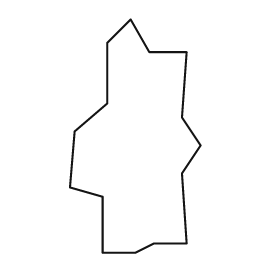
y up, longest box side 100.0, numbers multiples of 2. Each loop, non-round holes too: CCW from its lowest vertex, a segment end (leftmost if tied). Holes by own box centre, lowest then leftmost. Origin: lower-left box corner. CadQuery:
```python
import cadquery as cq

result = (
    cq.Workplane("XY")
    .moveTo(14.0, 0.0)
    .lineTo(28.0, 0.0)
    .lineTo(36.0, 4.0)
    .lineTo(50.0, 4.0)
    .lineTo(48.0, 34.0)
    .lineTo(56.0, 46.0)
    .lineTo(48.0, 58.0)
    .lineTo(50.0, 86.0)
    .lineTo(34.0, 86.0)
    .lineTo(26.0, 100.0)
    .lineTo(16.0, 90.0)
    .lineTo(16.0, 64.0)
    .lineTo(2.0, 52.0)
    .lineTo(0.0, 28.0)
    .lineTo(14.0, 24.0)
    .close()
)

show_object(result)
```